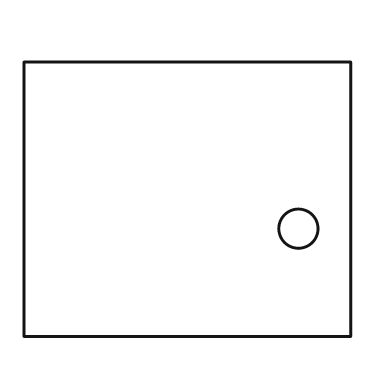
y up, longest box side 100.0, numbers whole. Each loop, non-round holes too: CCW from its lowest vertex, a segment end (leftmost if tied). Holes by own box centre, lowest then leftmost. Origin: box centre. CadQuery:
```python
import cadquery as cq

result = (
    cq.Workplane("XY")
    .moveTo(-50.0, -42.0)
    .lineTo(50.0, -42.0)
    .lineTo(50.0, 42.0)
    .lineTo(-50.0, 42.0)
    .close()
    .moveTo(34.0, -9.0)
    .circle(6.0)
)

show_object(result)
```